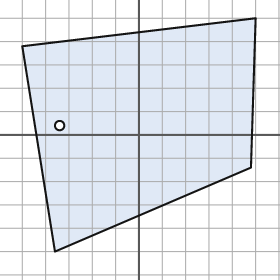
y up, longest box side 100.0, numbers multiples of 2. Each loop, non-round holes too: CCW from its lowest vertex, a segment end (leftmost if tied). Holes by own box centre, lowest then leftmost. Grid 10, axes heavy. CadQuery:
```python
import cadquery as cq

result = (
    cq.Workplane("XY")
    .moveTo(-36.0, -50.0)
    .lineTo(48.0, -14.0)
    .lineTo(50.0, 50.0)
    .lineTo(-50.0, 38.0)
    .close()
    .moveTo(-34.0, 4.0)
    .circle(2.0)
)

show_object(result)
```